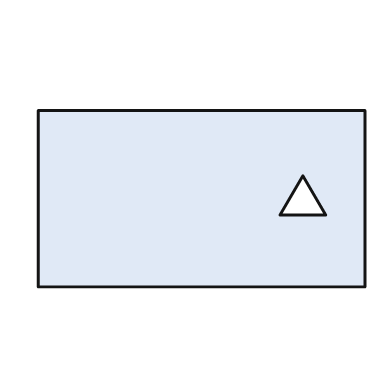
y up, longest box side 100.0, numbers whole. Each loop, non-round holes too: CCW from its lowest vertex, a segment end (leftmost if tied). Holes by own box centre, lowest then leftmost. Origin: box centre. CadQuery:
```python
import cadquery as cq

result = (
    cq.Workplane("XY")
    .moveTo(-50.0, -27.0)
    .lineTo(50.0, -27.0)
    .lineTo(50.0, 27.0)
    .lineTo(-50.0, 27.0)
    .close()
    .moveTo(24.0, -5.0)
    .lineTo(38.0, -5.0)
    .lineTo(31.0, 7.0)
    .close()
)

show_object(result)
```